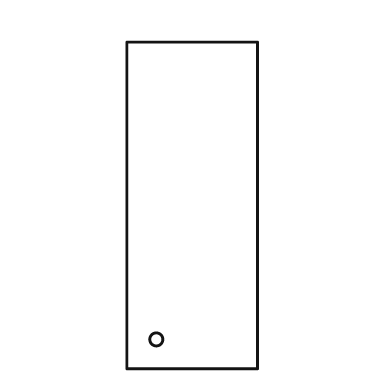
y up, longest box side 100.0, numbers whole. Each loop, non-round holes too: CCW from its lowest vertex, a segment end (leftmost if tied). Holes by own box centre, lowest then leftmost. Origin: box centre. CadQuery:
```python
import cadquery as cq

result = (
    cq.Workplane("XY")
    .moveTo(-20.0, -50.0)
    .lineTo(20.0, -50.0)
    .lineTo(20.0, 50.0)
    .lineTo(-20.0, 50.0)
    .close()
    .moveTo(-11.0, -41.0)
    .circle(2.0)
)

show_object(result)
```